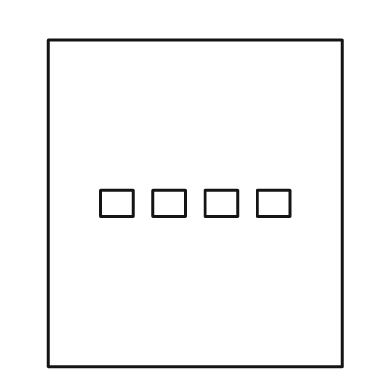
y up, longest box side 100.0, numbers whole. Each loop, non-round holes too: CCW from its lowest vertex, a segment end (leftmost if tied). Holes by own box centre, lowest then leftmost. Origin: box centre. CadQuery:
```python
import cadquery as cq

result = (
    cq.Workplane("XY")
    .moveTo(-45.0, -50.0)
    .lineTo(45.0, -50.0)
    .lineTo(45.0, 50.0)
    .lineTo(-45.0, 50.0)
    .close()
    .moveTo(-29.0, -4.0)
    .lineTo(-19.0, -4.0)
    .lineTo(-19.0, 4.0)
    .lineTo(-29.0, 4.0)
    .close()
    .moveTo(-13.0, -4.0)
    .lineTo(-3.0, -4.0)
    .lineTo(-3.0, 4.0)
    .lineTo(-13.0, 4.0)
    .close()
    .moveTo(3.0, -4.0)
    .lineTo(13.0, -4.0)
    .lineTo(13.0, 4.0)
    .lineTo(3.0, 4.0)
    .close()
    .moveTo(19.0, -4.0)
    .lineTo(29.0, -4.0)
    .lineTo(29.0, 4.0)
    .lineTo(19.0, 4.0)
    .close()
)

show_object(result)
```